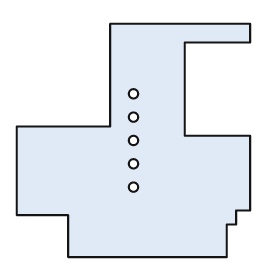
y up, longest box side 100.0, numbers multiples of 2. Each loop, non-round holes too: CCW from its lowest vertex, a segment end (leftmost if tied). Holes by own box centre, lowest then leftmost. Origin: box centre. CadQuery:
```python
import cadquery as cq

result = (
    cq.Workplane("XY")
    .moveTo(-28.0, -50.0)
    .lineTo(40.0, -50.0)
    .lineTo(40.0, -36.0)
    .lineTo(44.0, -36.0)
    .lineTo(44.0, -30.0)
    .lineTo(50.0, -30.0)
    .lineTo(50.0, 2.0)
    .lineTo(22.0, 2.0)
    .lineTo(22.0, 42.0)
    .lineTo(50.0, 42.0)
    .lineTo(50.0, 50.0)
    .lineTo(-10.0, 50.0)
    .lineTo(-10.0, 6.0)
    .lineTo(-50.0, 6.0)
    .lineTo(-50.0, -32.0)
    .lineTo(-28.0, -32.0)
    .close()
    .moveTo(0.0, -20.0)
    .circle(2.0)
    .moveTo(0.0, -10.0)
    .circle(2.0)
    .moveTo(0.0, 0.0)
    .circle(2.0)
    .moveTo(0.0, 10.0)
    .circle(2.0)
    .moveTo(0.0, 20.0)
    .circle(2.0)
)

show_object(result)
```